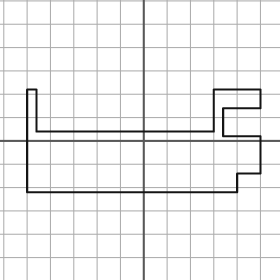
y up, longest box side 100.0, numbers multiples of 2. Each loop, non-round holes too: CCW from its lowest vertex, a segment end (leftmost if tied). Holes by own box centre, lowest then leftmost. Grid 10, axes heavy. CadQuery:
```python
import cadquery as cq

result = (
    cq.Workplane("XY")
    .moveTo(-50.0, -22.0)
    .lineTo(40.0, -22.0)
    .lineTo(40.0, -14.0)
    .lineTo(50.0, -14.0)
    .lineTo(50.0, 2.0)
    .lineTo(34.0, 2.0)
    .lineTo(34.0, 14.0)
    .lineTo(50.0, 14.0)
    .lineTo(50.0, 22.0)
    .lineTo(30.0, 22.0)
    .lineTo(30.0, 4.0)
    .lineTo(-46.0, 4.0)
    .lineTo(-46.0, 22.0)
    .lineTo(-50.0, 22.0)
    .close()
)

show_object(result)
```